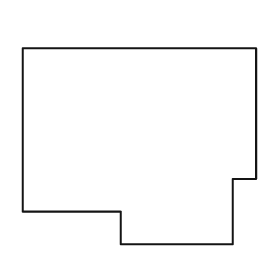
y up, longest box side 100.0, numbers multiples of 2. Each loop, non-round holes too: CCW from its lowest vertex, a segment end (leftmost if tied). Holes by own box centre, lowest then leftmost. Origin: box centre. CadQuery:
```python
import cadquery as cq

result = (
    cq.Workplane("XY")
    .moveTo(-8.0, -42.0)
    .lineTo(40.0, -42.0)
    .lineTo(40.0, -14.0)
    .lineTo(50.0, -14.0)
    .lineTo(50.0, 42.0)
    .lineTo(-50.0, 42.0)
    .lineTo(-50.0, -28.0)
    .lineTo(-8.0, -28.0)
    .close()
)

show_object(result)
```